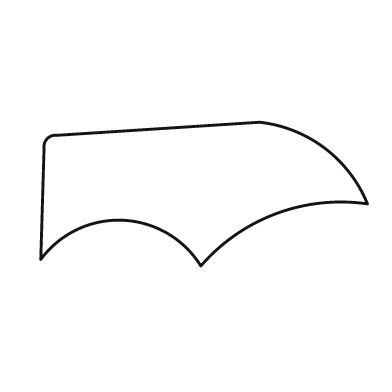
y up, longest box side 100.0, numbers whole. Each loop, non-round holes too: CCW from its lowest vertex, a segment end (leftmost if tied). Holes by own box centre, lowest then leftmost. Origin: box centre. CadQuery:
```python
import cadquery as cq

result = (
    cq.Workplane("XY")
    .moveTo(-1.0, -22.0)
    .threePointArc((22.0, -6.0), (50.0, -3.0))
    .threePointArc((37.0, 14.0), (17.0, 22.0))
    .lineTo(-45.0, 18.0)
    .threePointArc((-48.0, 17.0), (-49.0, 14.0))
    .lineTo(-50.0, -20.0)
    .threePointArc((-25.0, -8.0), (-1.0, -22.0))
    .close()
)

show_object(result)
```